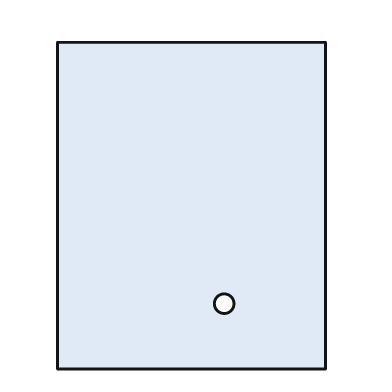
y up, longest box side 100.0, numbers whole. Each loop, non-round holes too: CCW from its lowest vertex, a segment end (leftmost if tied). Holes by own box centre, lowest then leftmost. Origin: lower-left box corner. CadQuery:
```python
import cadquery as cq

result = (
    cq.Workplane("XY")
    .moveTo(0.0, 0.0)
    .lineTo(82.0, 0.0)
    .lineTo(82.0, 100.0)
    .lineTo(0.0, 100.0)
    .close()
    .moveTo(51.0, 20.0)
    .circle(3.0)
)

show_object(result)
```